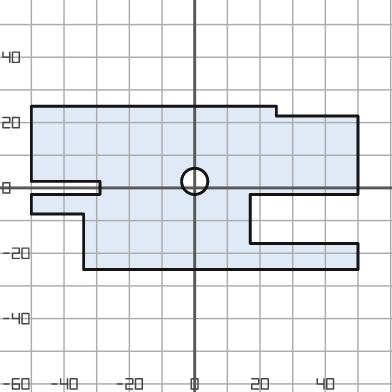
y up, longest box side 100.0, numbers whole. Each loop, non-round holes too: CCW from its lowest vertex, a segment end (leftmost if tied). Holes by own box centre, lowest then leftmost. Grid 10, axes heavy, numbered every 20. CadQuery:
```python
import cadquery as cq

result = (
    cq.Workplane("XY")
    .moveTo(-34.0, -25.0)
    .lineTo(50.0, -25.0)
    .lineTo(50.0, -17.0)
    .lineTo(17.0, -17.0)
    .lineTo(17.0, -2.0)
    .lineTo(50.0, -2.0)
    .lineTo(50.0, 22.0)
    .lineTo(25.0, 22.0)
    .lineTo(25.0, 25.0)
    .lineTo(-50.0, 25.0)
    .lineTo(-50.0, 2.0)
    .lineTo(-29.0, 2.0)
    .lineTo(-29.0, -2.0)
    .lineTo(-50.0, -2.0)
    .lineTo(-50.0, -8.0)
    .lineTo(-34.0, -8.0)
    .close()
    .moveTo(0.0, 2.0)
    .circle(4.0)
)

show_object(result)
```